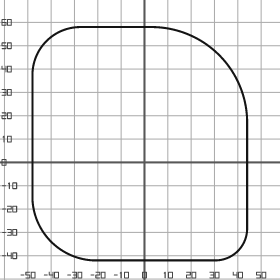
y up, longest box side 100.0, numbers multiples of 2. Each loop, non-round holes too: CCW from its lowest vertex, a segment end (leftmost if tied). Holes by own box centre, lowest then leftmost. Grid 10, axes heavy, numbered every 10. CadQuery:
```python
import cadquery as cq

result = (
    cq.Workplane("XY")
    .moveTo(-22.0, -42.0)
    .lineTo(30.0, -42.0)
    .threePointArc((40.0, -38.0), (44.0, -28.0))
    .lineTo(44.0, 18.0)
    .threePointArc((32.0, 46.0), (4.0, 58.0))
    .lineTo(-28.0, 58.0)
    .threePointArc((-42.0, 52.0), (-48.0, 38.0))
    .lineTo(-48.0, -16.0)
    .threePointArc((-40.0, -34.0), (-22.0, -42.0))
    .close()
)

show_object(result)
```